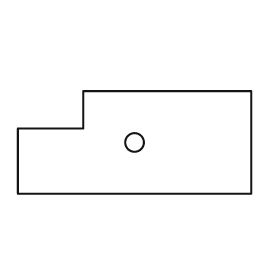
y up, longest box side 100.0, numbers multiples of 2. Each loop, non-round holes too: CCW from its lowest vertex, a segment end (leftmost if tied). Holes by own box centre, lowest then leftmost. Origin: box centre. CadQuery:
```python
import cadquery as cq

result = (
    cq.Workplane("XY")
    .moveTo(-50.0, -22.0)
    .lineTo(50.0, -22.0)
    .lineTo(50.0, 22.0)
    .lineTo(-22.0, 22.0)
    .lineTo(-22.0, 6.0)
    .lineTo(-50.0, 6.0)
    .close()
    .moveTo(0.0, 0.0)
    .circle(4.0)
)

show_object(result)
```